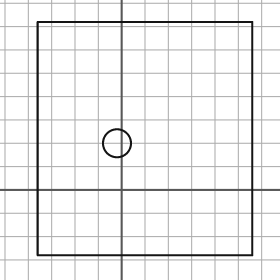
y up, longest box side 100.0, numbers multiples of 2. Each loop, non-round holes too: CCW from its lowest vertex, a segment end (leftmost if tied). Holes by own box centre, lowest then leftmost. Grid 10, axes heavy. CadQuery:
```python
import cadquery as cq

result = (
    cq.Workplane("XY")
    .moveTo(-36.0, -28.0)
    .lineTo(56.0, -28.0)
    .lineTo(56.0, 72.0)
    .lineTo(-36.0, 72.0)
    .close()
    .moveTo(-2.0, 20.0)
    .circle(6.0)
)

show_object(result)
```